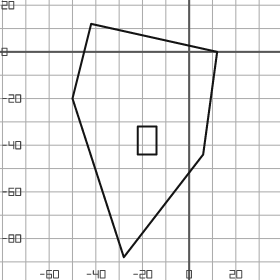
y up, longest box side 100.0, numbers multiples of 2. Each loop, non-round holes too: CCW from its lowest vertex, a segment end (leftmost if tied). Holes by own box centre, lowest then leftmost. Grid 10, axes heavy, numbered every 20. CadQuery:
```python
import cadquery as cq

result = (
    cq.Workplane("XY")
    .moveTo(-28.0, -88.0)
    .lineTo(6.0, -44.0)
    .lineTo(12.0, 0.0)
    .lineTo(-42.0, 12.0)
    .lineTo(-50.0, -20.0)
    .close()
    .moveTo(-22.0, -44.0)
    .lineTo(-14.0, -44.0)
    .lineTo(-14.0, -32.0)
    .lineTo(-22.0, -32.0)
    .close()
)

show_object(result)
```